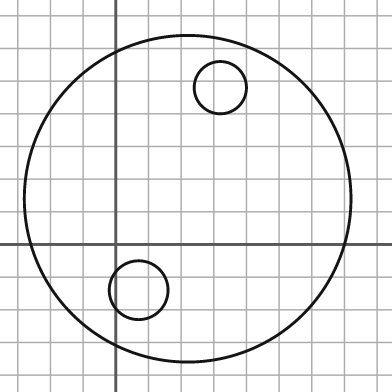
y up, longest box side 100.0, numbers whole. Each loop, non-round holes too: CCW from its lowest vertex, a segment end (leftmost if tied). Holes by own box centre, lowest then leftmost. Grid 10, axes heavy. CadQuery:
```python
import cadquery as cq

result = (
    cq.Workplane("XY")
    .moveTo(22.0, 14.0)
    .circle(50.0)
    .moveTo(7.0, -14.0)
    .circle(9.0)
    .moveTo(32.0, 48.0)
    .circle(8.0)
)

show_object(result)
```